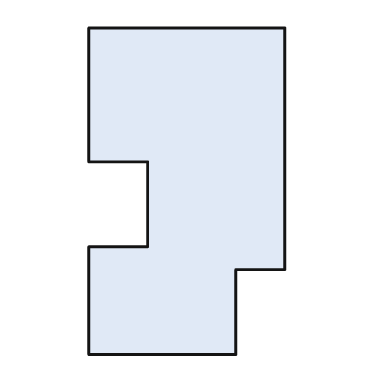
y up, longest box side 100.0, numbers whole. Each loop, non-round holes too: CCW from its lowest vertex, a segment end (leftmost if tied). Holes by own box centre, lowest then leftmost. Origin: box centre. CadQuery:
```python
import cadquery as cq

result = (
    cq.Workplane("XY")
    .moveTo(-30.0, -50.0)
    .lineTo(15.0, -50.0)
    .lineTo(15.0, -24.0)
    .lineTo(30.0, -24.0)
    .lineTo(30.0, 50.0)
    .lineTo(-30.0, 50.0)
    .lineTo(-30.0, 9.0)
    .lineTo(-12.0, 9.0)
    .lineTo(-12.0, -17.0)
    .lineTo(-30.0, -17.0)
    .close()
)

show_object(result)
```